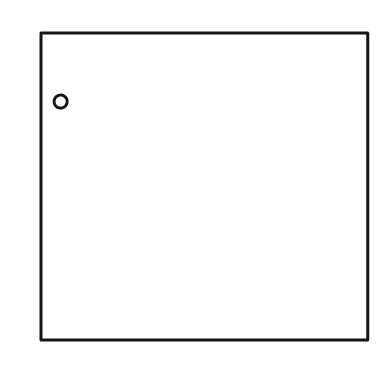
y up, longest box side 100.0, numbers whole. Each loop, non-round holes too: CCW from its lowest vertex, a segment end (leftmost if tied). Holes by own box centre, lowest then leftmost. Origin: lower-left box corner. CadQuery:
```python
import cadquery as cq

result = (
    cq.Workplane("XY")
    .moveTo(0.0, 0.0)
    .lineTo(100.0, 0.0)
    .lineTo(100.0, 94.0)
    .lineTo(0.0, 94.0)
    .close()
    .moveTo(6.0, 73.0)
    .circle(2.0)
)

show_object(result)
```